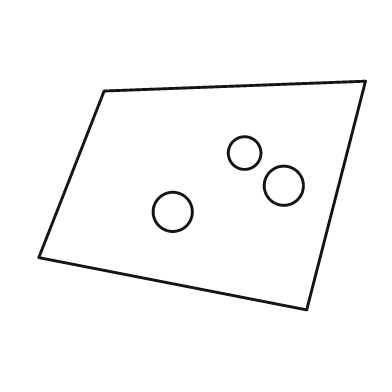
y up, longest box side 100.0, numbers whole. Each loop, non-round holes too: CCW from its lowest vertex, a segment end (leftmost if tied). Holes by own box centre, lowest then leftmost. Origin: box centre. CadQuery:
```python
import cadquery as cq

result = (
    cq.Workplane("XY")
    .moveTo(32.0, -35.0)
    .lineTo(50.0, 35.0)
    .lineTo(-30.0, 32.0)
    .lineTo(-50.0, -19.0)
    .close()
    .moveTo(-9.0, -5.0)
    .circle(6.0)
    .moveTo(25.0, 3.0)
    .circle(6.0)
    .moveTo(13.0, 13.0)
    .circle(5.0)
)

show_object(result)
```